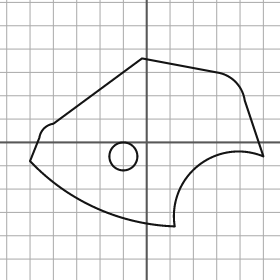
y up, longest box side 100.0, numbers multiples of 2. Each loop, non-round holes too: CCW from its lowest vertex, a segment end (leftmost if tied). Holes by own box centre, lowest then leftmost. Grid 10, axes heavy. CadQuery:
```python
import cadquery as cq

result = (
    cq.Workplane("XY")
    .moveTo(12.0, -36.0)
    .threePointArc((22.0, -10.0), (50.0, -6.0))
    .lineTo(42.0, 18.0)
    .threePointArc((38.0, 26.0), (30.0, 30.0))
    .lineTo(-2.0, 36.0)
    .lineTo(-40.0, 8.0)
    .threePointArc((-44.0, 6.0), (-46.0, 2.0))
    .lineTo(-50.0, -8.0)
    .threePointArc((-22.0, -28.0), (12.0, -36.0))
    .close()
    .moveTo(-10.0, -6.0)
    .circle(6.0)
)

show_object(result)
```